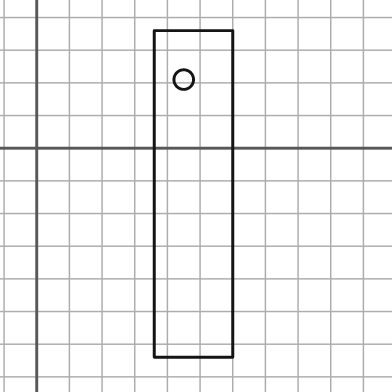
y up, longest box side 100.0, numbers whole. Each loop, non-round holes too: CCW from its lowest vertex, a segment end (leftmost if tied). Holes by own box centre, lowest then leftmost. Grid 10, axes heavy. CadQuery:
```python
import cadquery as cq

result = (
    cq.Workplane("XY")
    .moveTo(36.0, -64.0)
    .lineTo(60.0, -64.0)
    .lineTo(60.0, 36.0)
    .lineTo(36.0, 36.0)
    .close()
    .moveTo(45.0, 21.0)
    .circle(3.0)
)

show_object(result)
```